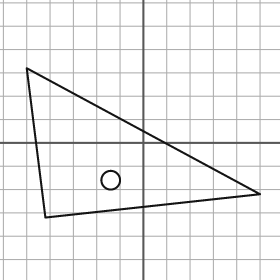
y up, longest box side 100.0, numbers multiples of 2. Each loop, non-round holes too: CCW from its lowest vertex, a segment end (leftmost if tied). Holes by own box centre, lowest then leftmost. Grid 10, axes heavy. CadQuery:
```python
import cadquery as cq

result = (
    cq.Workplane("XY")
    .moveTo(-42.0, -32.0)
    .lineTo(50.0, -22.0)
    .lineTo(-50.0, 32.0)
    .close()
    .moveTo(-14.0, -16.0)
    .circle(4.0)
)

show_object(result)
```